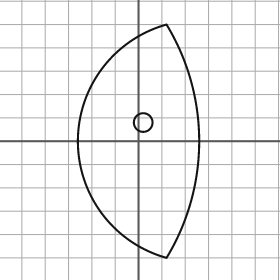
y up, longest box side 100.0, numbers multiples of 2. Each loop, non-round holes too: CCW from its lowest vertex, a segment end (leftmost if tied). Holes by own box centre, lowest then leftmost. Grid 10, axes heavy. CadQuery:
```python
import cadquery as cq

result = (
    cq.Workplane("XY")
    .moveTo(12.0, -50.0)
    .threePointArc((26.0, 0.0), (12.0, 50.0))
    .threePointArc((-26.0, 0.0), (12.0, -50.0))
    .close()
    .moveTo(2.0, 8.0)
    .circle(4.0)
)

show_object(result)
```